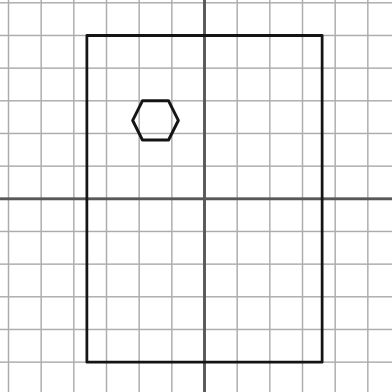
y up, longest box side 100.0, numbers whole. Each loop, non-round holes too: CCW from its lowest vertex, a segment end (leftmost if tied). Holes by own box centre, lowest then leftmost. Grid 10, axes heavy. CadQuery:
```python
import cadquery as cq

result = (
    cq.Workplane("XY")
    .moveTo(-36.0, -50.0)
    .lineTo(36.0, -50.0)
    .lineTo(36.0, 50.0)
    .lineTo(-36.0, 50.0)
    .close()
    .moveTo(-19.0, 18.0)
    .lineTo(-11.0, 18.0)
    .lineTo(-8.0, 24.0)
    .lineTo(-11.0, 30.0)
    .lineTo(-19.0, 30.0)
    .lineTo(-22.0, 24.0)
    .close()
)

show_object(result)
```